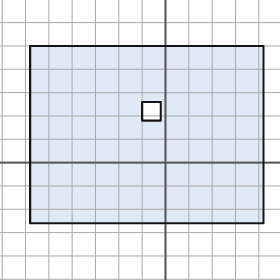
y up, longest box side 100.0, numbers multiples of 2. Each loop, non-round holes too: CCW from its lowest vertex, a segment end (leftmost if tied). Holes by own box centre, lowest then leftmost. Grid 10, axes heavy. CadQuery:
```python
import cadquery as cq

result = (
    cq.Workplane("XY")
    .moveTo(-58.0, -26.0)
    .lineTo(42.0, -26.0)
    .lineTo(42.0, 50.0)
    .lineTo(-58.0, 50.0)
    .close()
    .moveTo(-10.0, 18.0)
    .lineTo(-2.0, 18.0)
    .lineTo(-2.0, 26.0)
    .lineTo(-10.0, 26.0)
    .close()
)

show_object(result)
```